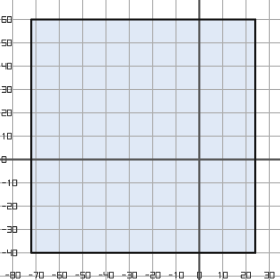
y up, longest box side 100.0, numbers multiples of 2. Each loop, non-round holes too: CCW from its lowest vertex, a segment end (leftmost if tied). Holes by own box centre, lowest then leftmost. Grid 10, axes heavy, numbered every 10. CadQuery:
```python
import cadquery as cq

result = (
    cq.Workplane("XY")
    .moveTo(-72.0, -40.0)
    .lineTo(24.0, -40.0)
    .lineTo(24.0, 60.0)
    .lineTo(-72.0, 60.0)
    .close()
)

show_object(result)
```